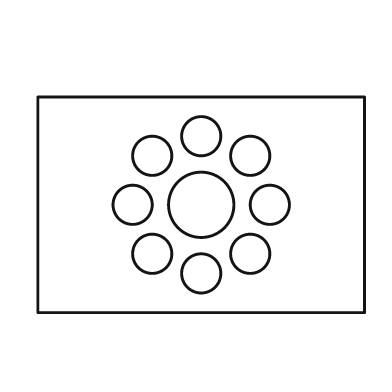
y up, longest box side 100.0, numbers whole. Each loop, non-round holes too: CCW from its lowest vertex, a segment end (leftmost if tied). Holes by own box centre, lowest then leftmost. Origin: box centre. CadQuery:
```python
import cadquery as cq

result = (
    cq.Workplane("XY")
    .moveTo(-50.0, -33.0)
    .lineTo(50.0, -33.0)
    .lineTo(50.0, 33.0)
    .lineTo(-50.0, 33.0)
    .close()
    .moveTo(0.0, -21.0)
    .circle(6.0)
    .moveTo(-15.0, -15.0)
    .circle(6.0)
    .moveTo(15.0, -15.0)
    .circle(6.0)
    .moveTo(-21.0, 0.0)
    .circle(6.0)
    .moveTo(0.0, 0.0)
    .circle(10.0)
    .moveTo(21.0, 0.0)
    .circle(6.0)
    .moveTo(-15.0, 15.0)
    .circle(6.0)
    .moveTo(15.0, 15.0)
    .circle(6.0)
    .moveTo(0.0, 21.0)
    .circle(6.0)
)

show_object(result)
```